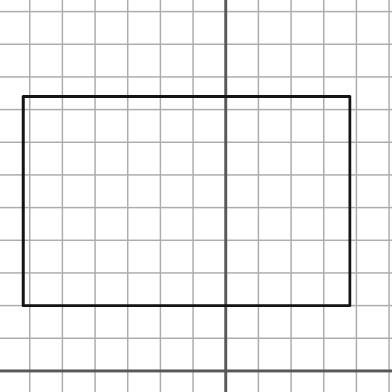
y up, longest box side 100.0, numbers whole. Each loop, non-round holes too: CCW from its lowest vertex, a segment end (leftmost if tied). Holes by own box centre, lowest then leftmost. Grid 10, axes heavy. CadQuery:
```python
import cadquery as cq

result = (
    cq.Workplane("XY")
    .moveTo(-62.0, 20.0)
    .lineTo(38.0, 20.0)
    .lineTo(38.0, 84.0)
    .lineTo(-62.0, 84.0)
    .close()
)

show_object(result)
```